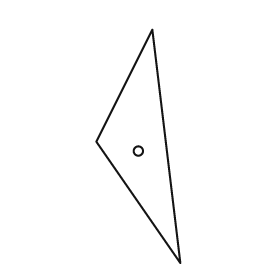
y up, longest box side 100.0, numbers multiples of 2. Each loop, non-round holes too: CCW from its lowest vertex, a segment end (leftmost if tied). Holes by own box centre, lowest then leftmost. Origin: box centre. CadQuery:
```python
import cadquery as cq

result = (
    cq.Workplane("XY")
    .moveTo(18.0, -50.0)
    .lineTo(6.0, 50.0)
    .lineTo(-18.0, 2.0)
    .close()
    .moveTo(0.0, -2.0)
    .circle(2.0)
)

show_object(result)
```